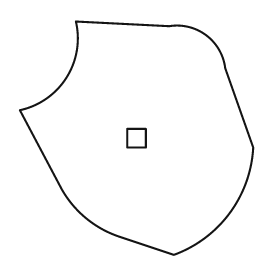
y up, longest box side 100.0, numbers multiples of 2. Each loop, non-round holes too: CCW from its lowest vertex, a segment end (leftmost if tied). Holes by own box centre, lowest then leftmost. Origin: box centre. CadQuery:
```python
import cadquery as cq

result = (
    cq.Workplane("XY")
    .moveTo(16.0, -50.0)
    .threePointArc((40.0, -32.0), (50.0, -4.0))
    .lineTo(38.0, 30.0)
    .threePointArc((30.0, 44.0), (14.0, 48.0))
    .lineTo(-26.0, 50.0)
    .threePointArc((-30.0, 26.0), (-50.0, 12.0))
    .lineTo(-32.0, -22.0)
    .threePointArc((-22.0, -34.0), (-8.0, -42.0))
    .close()
    .moveTo(-4.0, -4.0)
    .lineTo(4.0, -4.0)
    .lineTo(4.0, 4.0)
    .lineTo(-4.0, 4.0)
    .close()
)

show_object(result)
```